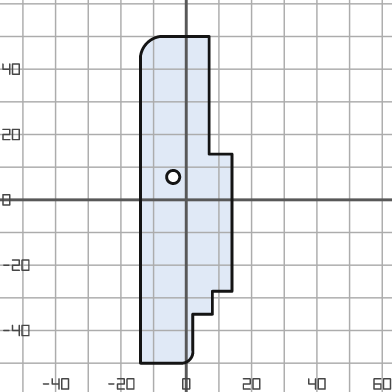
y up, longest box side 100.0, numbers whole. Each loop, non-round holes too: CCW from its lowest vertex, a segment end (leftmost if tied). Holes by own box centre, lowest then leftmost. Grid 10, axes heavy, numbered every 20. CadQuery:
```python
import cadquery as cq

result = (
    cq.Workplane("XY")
    .moveTo(-14.0, -50.0)
    .lineTo(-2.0, -50.0)
    .threePointArc((1.0, -49.0), (2.0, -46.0))
    .lineTo(2.0, -35.0)
    .lineTo(8.0, -35.0)
    .lineTo(8.0, -28.0)
    .lineTo(14.0, -28.0)
    .lineTo(14.0, 14.0)
    .lineTo(7.0, 14.0)
    .lineTo(7.0, 50.0)
    .lineTo(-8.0, 50.0)
    .threePointArc((-12.0, 48.0), (-14.0, 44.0))
    .close()
    .moveTo(-4.0, 7.0)
    .circle(2.0)
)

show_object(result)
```